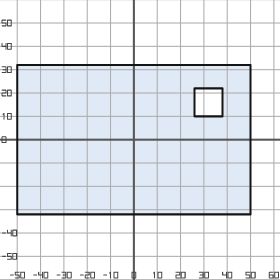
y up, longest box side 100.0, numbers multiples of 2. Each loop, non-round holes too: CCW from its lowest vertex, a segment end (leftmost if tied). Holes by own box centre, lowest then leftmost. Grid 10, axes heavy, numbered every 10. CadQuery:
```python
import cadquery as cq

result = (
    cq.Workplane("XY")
    .moveTo(-50.0, -32.0)
    .lineTo(50.0, -32.0)
    .lineTo(50.0, 32.0)
    .lineTo(-50.0, 32.0)
    .close()
    .moveTo(26.0, 10.0)
    .lineTo(38.0, 10.0)
    .lineTo(38.0, 22.0)
    .lineTo(26.0, 22.0)
    .close()
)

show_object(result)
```